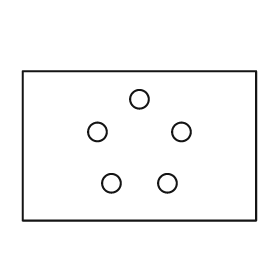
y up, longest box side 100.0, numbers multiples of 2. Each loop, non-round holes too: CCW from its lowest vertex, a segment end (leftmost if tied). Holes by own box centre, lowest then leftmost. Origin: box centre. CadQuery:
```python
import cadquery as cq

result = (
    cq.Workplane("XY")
    .moveTo(-50.0, -32.0)
    .lineTo(50.0, -32.0)
    .lineTo(50.0, 32.0)
    .lineTo(-50.0, 32.0)
    .close()
    .moveTo(-12.0, -16.0)
    .circle(4.0)
    .moveTo(12.0, -16.0)
    .circle(4.0)
    .moveTo(-18.0, 6.0)
    .circle(4.0)
    .moveTo(18.0, 6.0)
    .circle(4.0)
    .moveTo(0.0, 20.0)
    .circle(4.0)
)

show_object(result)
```